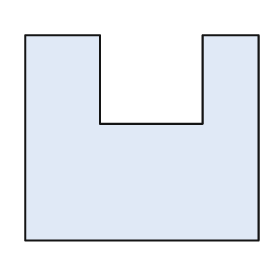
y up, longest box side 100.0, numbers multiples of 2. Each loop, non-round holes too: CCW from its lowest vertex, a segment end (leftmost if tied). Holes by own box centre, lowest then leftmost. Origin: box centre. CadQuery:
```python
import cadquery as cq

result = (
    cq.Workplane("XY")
    .moveTo(-50.0, -44.0)
    .lineTo(50.0, -44.0)
    .lineTo(50.0, 44.0)
    .lineTo(26.0, 44.0)
    .lineTo(26.0, 6.0)
    .lineTo(-18.0, 6.0)
    .lineTo(-18.0, 44.0)
    .lineTo(-50.0, 44.0)
    .close()
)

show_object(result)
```